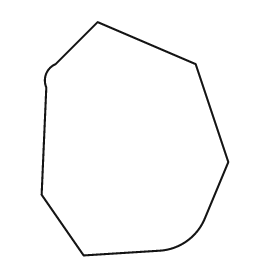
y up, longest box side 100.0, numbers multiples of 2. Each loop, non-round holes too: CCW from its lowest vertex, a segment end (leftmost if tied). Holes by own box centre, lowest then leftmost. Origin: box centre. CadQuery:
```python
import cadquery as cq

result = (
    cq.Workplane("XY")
    .moveTo(-22.0, -50.0)
    .lineTo(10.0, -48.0)
    .threePointArc((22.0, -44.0), (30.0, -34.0))
    .lineTo(40.0, -10.0)
    .lineTo(26.0, 32.0)
    .lineTo(-16.0, 50.0)
    .lineTo(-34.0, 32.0)
    .threePointArc((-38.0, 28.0), (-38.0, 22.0))
    .lineTo(-40.0, -24.0)
    .close()
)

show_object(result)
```